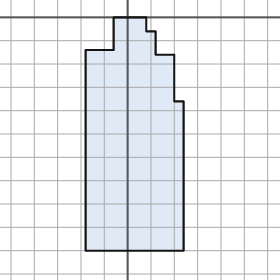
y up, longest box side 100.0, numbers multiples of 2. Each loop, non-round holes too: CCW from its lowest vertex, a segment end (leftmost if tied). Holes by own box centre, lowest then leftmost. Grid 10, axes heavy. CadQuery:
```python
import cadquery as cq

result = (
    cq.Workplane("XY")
    .moveTo(-18.0, -100.0)
    .lineTo(24.0, -100.0)
    .lineTo(24.0, -36.0)
    .lineTo(20.0, -36.0)
    .lineTo(20.0, -16.0)
    .lineTo(12.0, -16.0)
    .lineTo(12.0, -6.0)
    .lineTo(8.0, -6.0)
    .lineTo(8.0, 0.0)
    .lineTo(-6.0, 0.0)
    .lineTo(-6.0, -14.0)
    .lineTo(-18.0, -14.0)
    .close()
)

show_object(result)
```